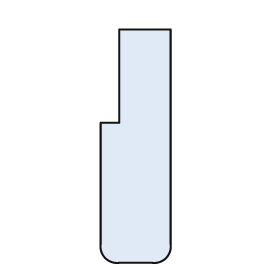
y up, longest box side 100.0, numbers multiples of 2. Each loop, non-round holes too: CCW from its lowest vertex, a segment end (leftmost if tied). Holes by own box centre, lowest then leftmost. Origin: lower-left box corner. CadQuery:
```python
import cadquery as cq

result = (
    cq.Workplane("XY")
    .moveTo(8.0, 0.0)
    .lineTo(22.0, 0.0)
    .threePointArc((28.0, 2.0), (30.0, 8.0))
    .lineTo(30.0, 100.0)
    .lineTo(8.0, 100.0)
    .lineTo(8.0, 60.0)
    .lineTo(0.0, 60.0)
    .lineTo(0.0, 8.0)
    .threePointArc((2.0, 2.0), (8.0, 0.0))
    .close()
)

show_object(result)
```